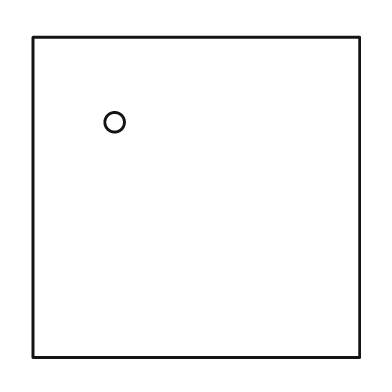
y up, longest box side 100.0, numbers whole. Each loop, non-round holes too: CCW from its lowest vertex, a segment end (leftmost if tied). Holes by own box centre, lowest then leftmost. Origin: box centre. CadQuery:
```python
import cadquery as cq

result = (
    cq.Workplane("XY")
    .moveTo(-50.0, -49.0)
    .lineTo(50.0, -49.0)
    .lineTo(50.0, 49.0)
    .lineTo(-50.0, 49.0)
    .close()
    .moveTo(-25.0, 23.0)
    .circle(3.0)
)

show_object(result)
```